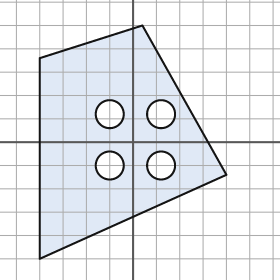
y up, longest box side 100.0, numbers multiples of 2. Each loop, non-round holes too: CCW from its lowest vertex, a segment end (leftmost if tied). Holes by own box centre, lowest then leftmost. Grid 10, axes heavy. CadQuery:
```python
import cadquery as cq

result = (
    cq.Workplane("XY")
    .moveTo(-40.0, -50.0)
    .lineTo(40.0, -14.0)
    .lineTo(4.0, 50.0)
    .lineTo(-40.0, 36.0)
    .close()
    .moveTo(-10.0, -10.0)
    .circle(6.0)
    .moveTo(12.0, -10.0)
    .circle(6.0)
    .moveTo(-10.0, 12.0)
    .circle(6.0)
    .moveTo(12.0, 12.0)
    .circle(6.0)
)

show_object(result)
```